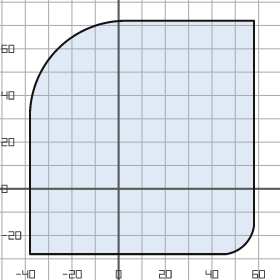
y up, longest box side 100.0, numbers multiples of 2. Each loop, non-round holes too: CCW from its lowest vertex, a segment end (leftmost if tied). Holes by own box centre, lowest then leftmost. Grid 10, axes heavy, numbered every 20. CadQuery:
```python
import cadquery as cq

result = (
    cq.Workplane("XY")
    .moveTo(-38.0, -28.0)
    .lineTo(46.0, -28.0)
    .threePointArc((54.0, -24.0), (58.0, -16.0))
    .lineTo(58.0, 72.0)
    .lineTo(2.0, 72.0)
    .threePointArc((-26.0, 60.0), (-38.0, 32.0))
    .close()
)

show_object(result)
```